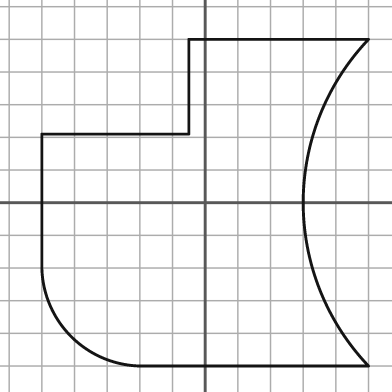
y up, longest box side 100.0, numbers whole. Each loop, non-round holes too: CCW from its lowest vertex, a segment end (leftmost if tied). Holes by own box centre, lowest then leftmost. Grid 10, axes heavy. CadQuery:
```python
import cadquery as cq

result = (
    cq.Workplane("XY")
    .moveTo(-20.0, -50.0)
    .lineTo(50.0, -50.0)
    .threePointArc((30.0, 0.0), (50.0, 50.0))
    .lineTo(-5.0, 50.0)
    .lineTo(-5.0, 21.0)
    .lineTo(-50.0, 21.0)
    .lineTo(-50.0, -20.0)
    .threePointArc((-41.0, -41.0), (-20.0, -50.0))
    .close()
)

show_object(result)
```